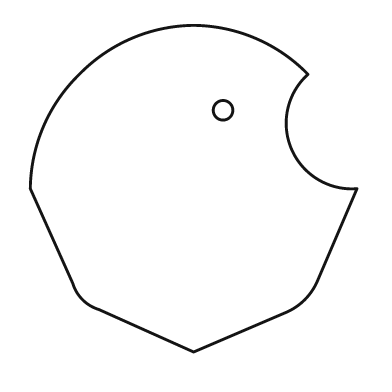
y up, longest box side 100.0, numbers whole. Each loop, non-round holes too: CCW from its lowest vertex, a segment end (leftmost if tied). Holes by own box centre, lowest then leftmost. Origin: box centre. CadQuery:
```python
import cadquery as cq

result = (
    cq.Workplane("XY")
    .moveTo(0.0, -50.0)
    .lineTo(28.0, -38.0)
    .threePointArc((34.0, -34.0), (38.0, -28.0))
    .lineTo(50.0, 0.0)
    .threePointArc((30.0, 12.0), (35.0, 35.0))
    .threePointArc((19.0, 46.0), (0.0, 50.0))
    .threePointArc((-19.0, 46.0), (-35.0, 35.0))
    .threePointArc((-46.0, 19.0), (-50.0, 0.0))
    .lineTo(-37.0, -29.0)
    .threePointArc((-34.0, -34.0), (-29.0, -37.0))
    .close()
    .moveTo(9.0, 24.0)
    .circle(3.0)
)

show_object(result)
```